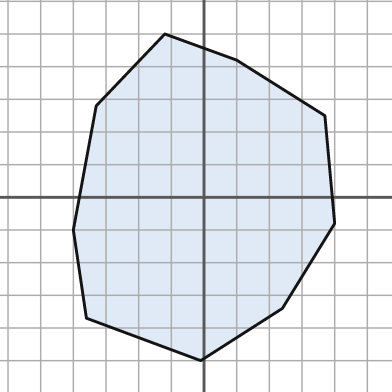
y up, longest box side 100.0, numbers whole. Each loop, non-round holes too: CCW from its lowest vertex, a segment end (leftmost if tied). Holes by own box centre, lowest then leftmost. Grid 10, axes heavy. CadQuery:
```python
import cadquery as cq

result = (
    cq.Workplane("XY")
    .moveTo(-1.0, -50.0)
    .lineTo(24.0, -34.0)
    .lineTo(40.0, -8.0)
    .lineTo(37.0, 25.0)
    .lineTo(10.0, 42.0)
    .lineTo(-12.0, 50.0)
    .lineTo(-33.0, 28.0)
    .lineTo(-40.0, -10.0)
    .lineTo(-36.0, -37.0)
    .close()
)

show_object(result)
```